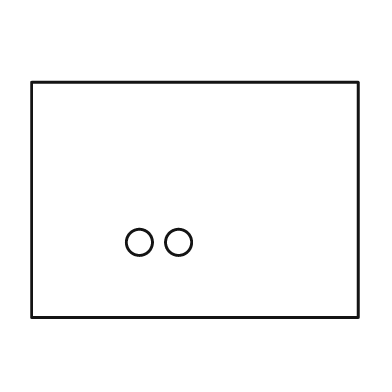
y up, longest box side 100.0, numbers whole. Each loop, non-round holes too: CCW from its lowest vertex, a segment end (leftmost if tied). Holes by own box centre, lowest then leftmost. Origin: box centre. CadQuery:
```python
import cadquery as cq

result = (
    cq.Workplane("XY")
    .moveTo(-50.0, -36.0)
    .lineTo(50.0, -36.0)
    .lineTo(50.0, 36.0)
    .lineTo(-50.0, 36.0)
    .close()
    .moveTo(-17.0, -13.0)
    .circle(4.0)
    .moveTo(-5.0, -13.0)
    .circle(4.0)
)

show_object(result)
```